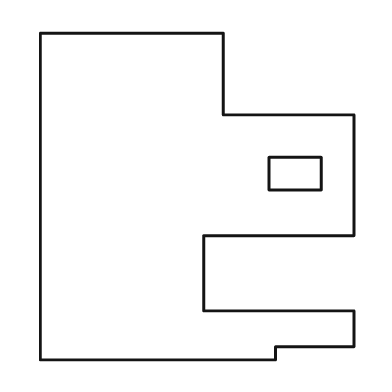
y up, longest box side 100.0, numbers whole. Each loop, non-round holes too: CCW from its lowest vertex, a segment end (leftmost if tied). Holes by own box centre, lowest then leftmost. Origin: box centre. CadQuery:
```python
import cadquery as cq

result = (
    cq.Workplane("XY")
    .moveTo(-48.0, -50.0)
    .lineTo(24.0, -50.0)
    .lineTo(24.0, -46.0)
    .lineTo(48.0, -46.0)
    .lineTo(48.0, -35.0)
    .lineTo(2.0, -35.0)
    .lineTo(2.0, -12.0)
    .lineTo(48.0, -12.0)
    .lineTo(48.0, 25.0)
    .lineTo(8.0, 25.0)
    .lineTo(8.0, 50.0)
    .lineTo(-48.0, 50.0)
    .close()
    .moveTo(22.0, 2.0)
    .lineTo(38.0, 2.0)
    .lineTo(38.0, 12.0)
    .lineTo(22.0, 12.0)
    .close()
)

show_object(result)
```